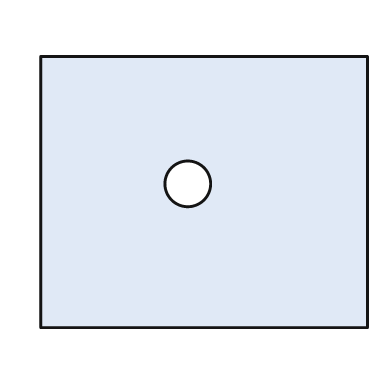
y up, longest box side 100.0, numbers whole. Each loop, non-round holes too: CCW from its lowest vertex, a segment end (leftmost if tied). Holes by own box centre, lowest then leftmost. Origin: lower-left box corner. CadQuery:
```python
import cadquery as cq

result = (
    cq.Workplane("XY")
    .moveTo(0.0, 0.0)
    .lineTo(100.0, 0.0)
    .lineTo(100.0, 83.0)
    .lineTo(0.0, 83.0)
    .close()
    .moveTo(45.0, 44.0)
    .circle(7.0)
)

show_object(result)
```